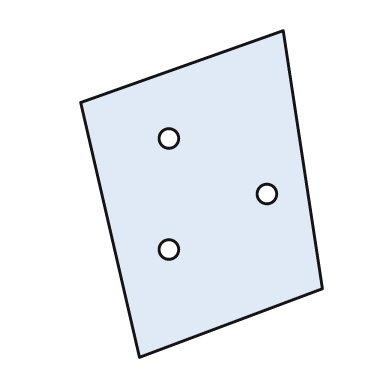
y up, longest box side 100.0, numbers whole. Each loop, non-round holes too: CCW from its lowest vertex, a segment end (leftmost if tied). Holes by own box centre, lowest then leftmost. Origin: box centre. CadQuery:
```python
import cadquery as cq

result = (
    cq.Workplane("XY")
    .moveTo(-19.0, -50.0)
    .lineTo(37.0, -29.0)
    .lineTo(25.0, 50.0)
    .lineTo(-37.0, 28.0)
    .close()
    .moveTo(-10.0, -17.0)
    .circle(3.0)
    .moveTo(20.0, 0.0)
    .circle(3.0)
    .moveTo(-10.0, 17.0)
    .circle(3.0)
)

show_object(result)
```